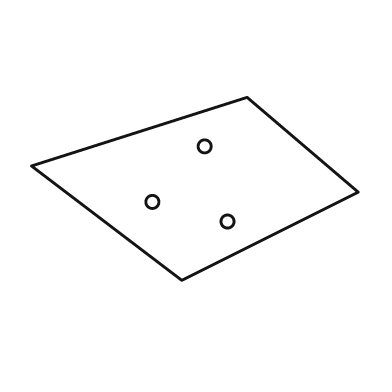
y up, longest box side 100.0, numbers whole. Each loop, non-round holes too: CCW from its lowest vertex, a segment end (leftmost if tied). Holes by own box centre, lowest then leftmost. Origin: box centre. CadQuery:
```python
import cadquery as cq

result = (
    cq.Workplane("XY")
    .moveTo(-4.0, -28.0)
    .lineTo(50.0, -1.0)
    .lineTo(16.0, 28.0)
    .lineTo(-50.0, 7.0)
    .close()
    .moveTo(10.0, -10.0)
    .circle(2.0)
    .moveTo(-13.0, -4.0)
    .circle(2.0)
    .moveTo(3.0, 13.0)
    .circle(2.0)
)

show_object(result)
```